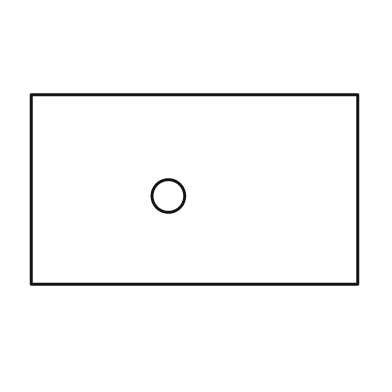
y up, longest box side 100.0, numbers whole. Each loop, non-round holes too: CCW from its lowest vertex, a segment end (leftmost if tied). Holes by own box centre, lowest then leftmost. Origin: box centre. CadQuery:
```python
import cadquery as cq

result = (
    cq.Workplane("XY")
    .moveTo(-50.0, -29.0)
    .lineTo(50.0, -29.0)
    .lineTo(50.0, 29.0)
    .lineTo(-50.0, 29.0)
    .close()
    .moveTo(-8.0, -2.0)
    .circle(5.0)
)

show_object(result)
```